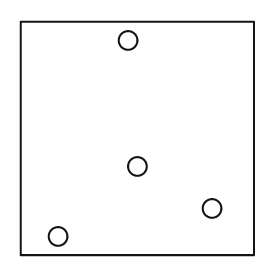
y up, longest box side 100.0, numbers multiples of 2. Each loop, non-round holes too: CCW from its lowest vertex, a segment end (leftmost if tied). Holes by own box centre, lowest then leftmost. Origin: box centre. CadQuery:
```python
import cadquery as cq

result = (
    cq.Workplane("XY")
    .moveTo(-50.0, -50.0)
    .lineTo(50.0, -50.0)
    .lineTo(50.0, 50.0)
    .lineTo(-50.0, 50.0)
    .close()
    .moveTo(-34.0, -42.0)
    .circle(4.0)
    .moveTo(32.0, -30.0)
    .circle(4.0)
    .moveTo(0.0, -12.0)
    .circle(4.0)
    .moveTo(-4.0, 42.0)
    .circle(4.0)
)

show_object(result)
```